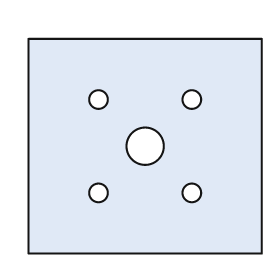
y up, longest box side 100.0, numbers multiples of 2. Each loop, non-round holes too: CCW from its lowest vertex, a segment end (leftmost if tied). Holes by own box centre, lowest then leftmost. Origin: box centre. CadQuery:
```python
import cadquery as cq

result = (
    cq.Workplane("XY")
    .moveTo(-50.0, -46.0)
    .lineTo(50.0, -46.0)
    .lineTo(50.0, 46.0)
    .lineTo(-50.0, 46.0)
    .close()
    .moveTo(-20.0, -20.0)
    .circle(4.0)
    .moveTo(20.0, -20.0)
    .circle(4.0)
    .moveTo(0.0, 0.0)
    .circle(8.0)
    .moveTo(-20.0, 20.0)
    .circle(4.0)
    .moveTo(20.0, 20.0)
    .circle(4.0)
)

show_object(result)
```